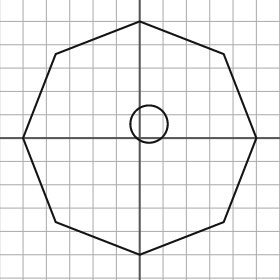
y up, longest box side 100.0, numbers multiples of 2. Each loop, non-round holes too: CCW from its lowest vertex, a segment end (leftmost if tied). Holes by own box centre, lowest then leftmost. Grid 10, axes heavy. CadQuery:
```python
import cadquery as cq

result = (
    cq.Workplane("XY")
    .moveTo(0.0, -50.0)
    .lineTo(36.0, -36.0)
    .lineTo(50.0, 0.0)
    .lineTo(36.0, 36.0)
    .lineTo(0.0, 50.0)
    .lineTo(-36.0, 36.0)
    .lineTo(-50.0, 0.0)
    .lineTo(-36.0, -36.0)
    .close()
    .moveTo(4.0, 6.0)
    .circle(8.0)
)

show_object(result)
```